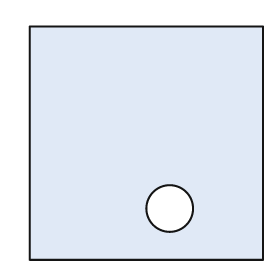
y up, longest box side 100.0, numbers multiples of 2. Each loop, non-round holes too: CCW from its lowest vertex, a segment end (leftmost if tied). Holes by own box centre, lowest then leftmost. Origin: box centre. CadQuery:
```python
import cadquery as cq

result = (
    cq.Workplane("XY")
    .moveTo(-50.0, -50.0)
    .lineTo(50.0, -50.0)
    .lineTo(50.0, 50.0)
    .lineTo(-50.0, 50.0)
    .close()
    .moveTo(10.0, -28.0)
    .circle(10.0)
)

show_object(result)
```